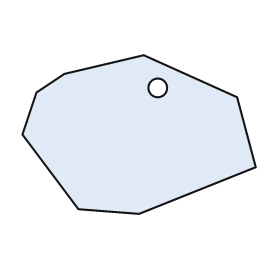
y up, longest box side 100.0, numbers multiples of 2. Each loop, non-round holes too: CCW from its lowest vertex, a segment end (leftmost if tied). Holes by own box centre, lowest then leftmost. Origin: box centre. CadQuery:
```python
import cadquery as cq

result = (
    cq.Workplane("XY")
    .moveTo(0.0, -34.0)
    .lineTo(50.0, -14.0)
    .lineTo(42.0, 16.0)
    .lineTo(2.0, 34.0)
    .lineTo(-32.0, 26.0)
    .lineTo(-44.0, 18.0)
    .lineTo(-50.0, 0.0)
    .lineTo(-26.0, -32.0)
    .close()
    .moveTo(8.0, 20.0)
    .circle(4.0)
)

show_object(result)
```